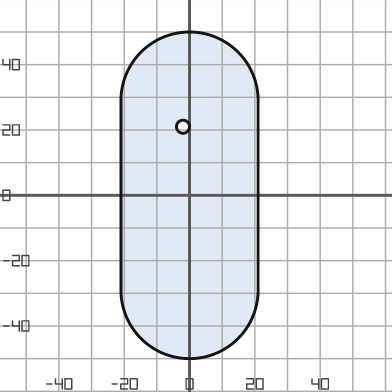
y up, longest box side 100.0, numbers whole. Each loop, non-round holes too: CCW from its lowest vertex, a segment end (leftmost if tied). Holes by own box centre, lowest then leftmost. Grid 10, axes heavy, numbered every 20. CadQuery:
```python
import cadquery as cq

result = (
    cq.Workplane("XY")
    .moveTo(-21.0, -29.0)
    .threePointArc((0.0, -50.0), (21.0, -29.0))
    .lineTo(21.0, 29.0)
    .threePointArc((0.0, 50.0), (-21.0, 29.0))
    .close()
    .moveTo(-2.0, 21.0)
    .circle(2.0)
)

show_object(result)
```